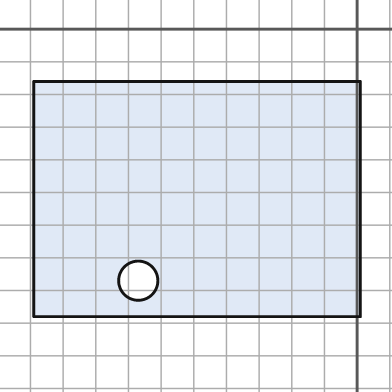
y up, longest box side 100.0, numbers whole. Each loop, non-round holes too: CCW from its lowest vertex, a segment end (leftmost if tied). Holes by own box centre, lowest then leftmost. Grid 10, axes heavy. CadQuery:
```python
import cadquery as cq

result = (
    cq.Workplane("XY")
    .moveTo(-99.0, -88.0)
    .lineTo(1.0, -88.0)
    .lineTo(1.0, -16.0)
    .lineTo(-99.0, -16.0)
    .close()
    .moveTo(-67.0, -77.0)
    .circle(6.0)
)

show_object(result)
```